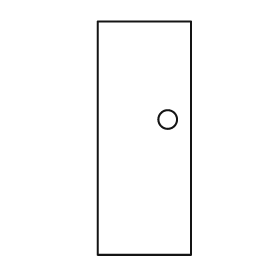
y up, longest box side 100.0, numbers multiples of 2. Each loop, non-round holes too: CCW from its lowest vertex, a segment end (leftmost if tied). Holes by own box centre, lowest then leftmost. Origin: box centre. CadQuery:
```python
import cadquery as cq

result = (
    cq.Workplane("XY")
    .moveTo(-20.0, -50.0)
    .lineTo(20.0, -50.0)
    .lineTo(20.0, 50.0)
    .lineTo(-20.0, 50.0)
    .close()
    .moveTo(10.0, 8.0)
    .circle(4.0)
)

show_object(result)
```